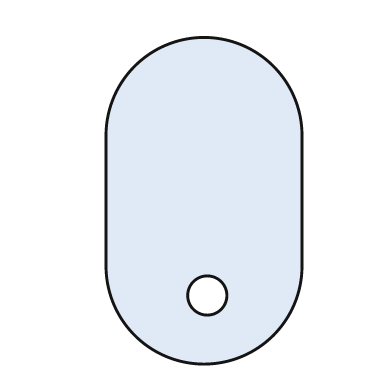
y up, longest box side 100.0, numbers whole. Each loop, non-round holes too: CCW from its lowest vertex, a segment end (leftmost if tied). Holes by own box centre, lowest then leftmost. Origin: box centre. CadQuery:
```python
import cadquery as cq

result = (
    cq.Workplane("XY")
    .moveTo(-30.0, -20.0)
    .threePointArc((0.0, -50.0), (30.0, -20.0))
    .lineTo(30.0, 20.0)
    .threePointArc((0.0, 50.0), (-30.0, 20.0))
    .close()
    .moveTo(1.0, -29.0)
    .circle(6.0)
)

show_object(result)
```